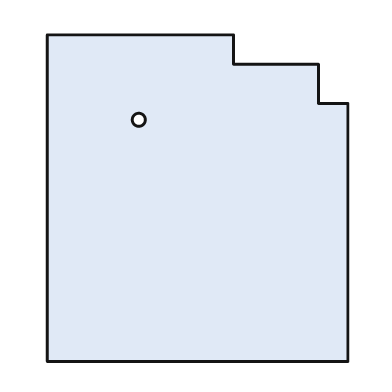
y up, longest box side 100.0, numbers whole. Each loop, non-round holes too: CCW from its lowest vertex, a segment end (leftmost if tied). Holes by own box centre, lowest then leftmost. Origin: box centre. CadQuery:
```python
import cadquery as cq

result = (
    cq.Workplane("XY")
    .moveTo(-46.0, -50.0)
    .lineTo(46.0, -50.0)
    .lineTo(46.0, 29.0)
    .lineTo(37.0, 29.0)
    .lineTo(37.0, 41.0)
    .lineTo(11.0, 41.0)
    .lineTo(11.0, 50.0)
    .lineTo(-46.0, 50.0)
    .close()
    .moveTo(-18.0, 24.0)
    .circle(2.0)
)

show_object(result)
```